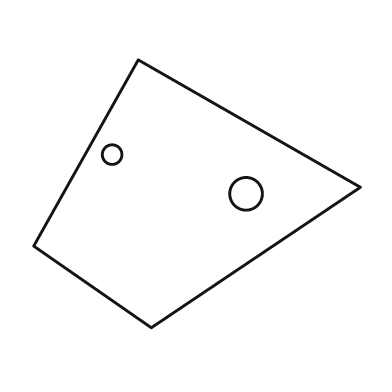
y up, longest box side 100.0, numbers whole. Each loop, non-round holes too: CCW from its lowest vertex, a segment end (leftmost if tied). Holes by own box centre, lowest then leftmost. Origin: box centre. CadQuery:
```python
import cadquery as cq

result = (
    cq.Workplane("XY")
    .moveTo(-14.0, -41.0)
    .lineTo(50.0, 2.0)
    .lineTo(-18.0, 41.0)
    .lineTo(-50.0, -16.0)
    .close()
    .moveTo(15.0, 0.0)
    .circle(5.0)
    .moveTo(-26.0, 12.0)
    .circle(3.0)
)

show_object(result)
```